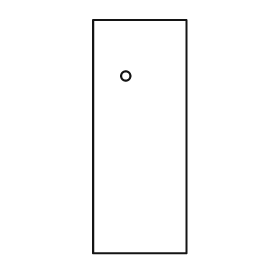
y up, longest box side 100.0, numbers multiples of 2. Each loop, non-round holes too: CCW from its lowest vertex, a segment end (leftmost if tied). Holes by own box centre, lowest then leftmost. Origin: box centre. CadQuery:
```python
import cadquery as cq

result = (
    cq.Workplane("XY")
    .moveTo(-20.0, -50.0)
    .lineTo(20.0, -50.0)
    .lineTo(20.0, 50.0)
    .lineTo(-20.0, 50.0)
    .close()
    .moveTo(-6.0, 26.0)
    .circle(2.0)
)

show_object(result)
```